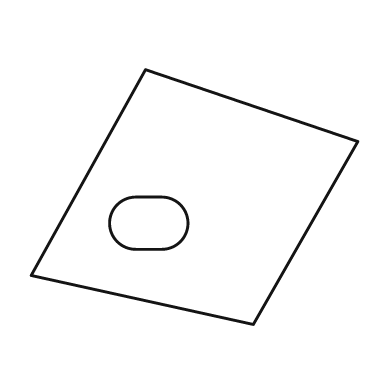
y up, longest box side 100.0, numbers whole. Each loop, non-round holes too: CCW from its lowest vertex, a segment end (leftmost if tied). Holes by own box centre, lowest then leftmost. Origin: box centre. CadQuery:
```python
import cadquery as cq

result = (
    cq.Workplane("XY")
    .moveTo(18.0, -39.0)
    .lineTo(50.0, 17.0)
    .lineTo(-15.0, 39.0)
    .lineTo(-50.0, -24.0)
    .close()
    .moveTo(-18.0, -16.0)
    .lineTo(-10.0, -16.0)
    .threePointArc((-2.0, -8.0), (-10.0, 0.0))
    .lineTo(-18.0, 0.0)
    .threePointArc((-26.0, -8.0), (-18.0, -16.0))
    .close()
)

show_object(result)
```